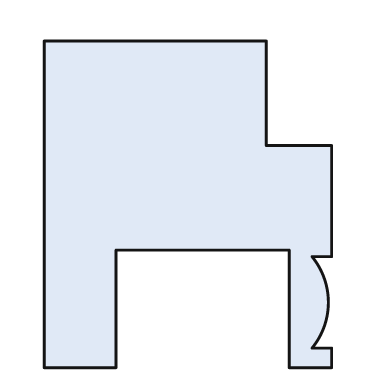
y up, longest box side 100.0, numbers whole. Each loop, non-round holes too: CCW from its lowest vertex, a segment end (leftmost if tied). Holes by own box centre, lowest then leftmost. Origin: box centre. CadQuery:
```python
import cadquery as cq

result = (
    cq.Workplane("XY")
    .moveTo(-44.0, -50.0)
    .lineTo(-22.0, -50.0)
    .lineTo(-22.0, -14.0)
    .lineTo(31.0, -14.0)
    .lineTo(31.0, -50.0)
    .lineTo(44.0, -50.0)
    .lineTo(44.0, -44.0)
    .lineTo(38.0, -44.0)
    .threePointArc((43.0, -30.0), (38.0, -16.0))
    .lineTo(44.0, -16.0)
    .lineTo(44.0, 18.0)
    .lineTo(24.0, 18.0)
    .lineTo(24.0, 50.0)
    .lineTo(-44.0, 50.0)
    .close()
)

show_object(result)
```